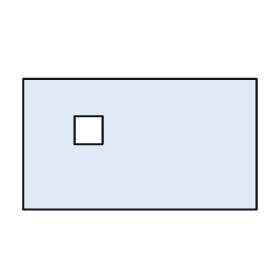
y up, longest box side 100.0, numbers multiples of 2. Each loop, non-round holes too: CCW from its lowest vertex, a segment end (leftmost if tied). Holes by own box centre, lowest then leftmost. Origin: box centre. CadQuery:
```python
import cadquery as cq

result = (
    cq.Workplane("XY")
    .moveTo(-50.0, -28.0)
    .lineTo(50.0, -28.0)
    .lineTo(50.0, 28.0)
    .lineTo(-50.0, 28.0)
    .close()
    .moveTo(-28.0, 0.0)
    .lineTo(-16.0, 0.0)
    .lineTo(-16.0, 12.0)
    .lineTo(-28.0, 12.0)
    .close()
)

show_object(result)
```